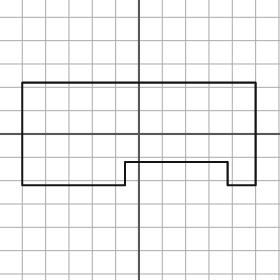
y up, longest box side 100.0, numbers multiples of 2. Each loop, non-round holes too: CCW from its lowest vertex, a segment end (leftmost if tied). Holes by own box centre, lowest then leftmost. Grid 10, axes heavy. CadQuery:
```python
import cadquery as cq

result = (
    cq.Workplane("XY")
    .moveTo(-50.0, -22.0)
    .lineTo(-6.0, -22.0)
    .lineTo(-6.0, -12.0)
    .lineTo(38.0, -12.0)
    .lineTo(38.0, -22.0)
    .lineTo(50.0, -22.0)
    .lineTo(50.0, 22.0)
    .lineTo(-50.0, 22.0)
    .close()
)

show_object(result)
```